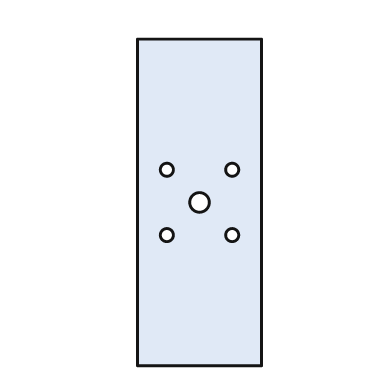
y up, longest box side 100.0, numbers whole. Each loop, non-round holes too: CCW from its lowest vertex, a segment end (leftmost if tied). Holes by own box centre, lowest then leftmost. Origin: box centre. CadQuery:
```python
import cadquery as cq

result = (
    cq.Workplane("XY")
    .moveTo(-19.0, -50.0)
    .lineTo(19.0, -50.0)
    .lineTo(19.0, 50.0)
    .lineTo(-19.0, 50.0)
    .close()
    .moveTo(-10.0, -10.0)
    .circle(2.0)
    .moveTo(10.0, -10.0)
    .circle(2.0)
    .moveTo(0.0, 0.0)
    .circle(3.0)
    .moveTo(-10.0, 10.0)
    .circle(2.0)
    .moveTo(10.0, 10.0)
    .circle(2.0)
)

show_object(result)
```